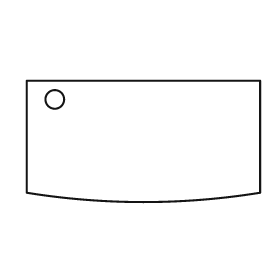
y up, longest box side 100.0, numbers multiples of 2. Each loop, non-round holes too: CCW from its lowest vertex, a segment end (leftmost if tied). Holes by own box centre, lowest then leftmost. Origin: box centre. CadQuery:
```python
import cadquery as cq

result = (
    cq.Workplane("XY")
    .moveTo(-50.0, -22.0)
    .threePointArc((0.0, -26.0), (50.0, -22.0))
    .lineTo(50.0, 26.0)
    .lineTo(-50.0, 26.0)
    .close()
    .moveTo(-38.0, 18.0)
    .circle(4.0)
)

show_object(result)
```